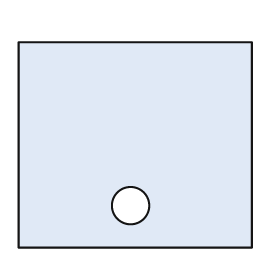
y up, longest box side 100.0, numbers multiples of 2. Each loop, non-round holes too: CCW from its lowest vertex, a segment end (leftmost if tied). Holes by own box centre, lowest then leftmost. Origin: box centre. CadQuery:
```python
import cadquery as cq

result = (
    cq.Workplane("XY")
    .moveTo(-50.0, -44.0)
    .lineTo(50.0, -44.0)
    .lineTo(50.0, 44.0)
    .lineTo(-50.0, 44.0)
    .close()
    .moveTo(-2.0, -26.0)
    .circle(8.0)
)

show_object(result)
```